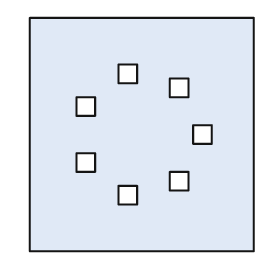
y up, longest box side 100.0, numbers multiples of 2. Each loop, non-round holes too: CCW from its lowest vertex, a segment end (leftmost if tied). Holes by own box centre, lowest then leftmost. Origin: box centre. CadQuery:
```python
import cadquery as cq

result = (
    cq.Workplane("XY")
    .moveTo(-48.0, -50.0)
    .lineTo(48.0, -50.0)
    .lineTo(48.0, 50.0)
    .lineTo(-48.0, 50.0)
    .close()
    .moveTo(-10.0, -30.0)
    .lineTo(-2.0, -30.0)
    .lineTo(-2.0, -22.0)
    .lineTo(-10.0, -22.0)
    .close()
    .moveTo(12.0, -24.0)
    .lineTo(20.0, -24.0)
    .lineTo(20.0, -16.0)
    .lineTo(12.0, -16.0)
    .close()
    .moveTo(-28.0, -16.0)
    .lineTo(-20.0, -16.0)
    .lineTo(-20.0, -8.0)
    .lineTo(-28.0, -8.0)
    .close()
    .moveTo(22.0, -4.0)
    .lineTo(30.0, -4.0)
    .lineTo(30.0, 4.0)
    .lineTo(22.0, 4.0)
    .close()
    .moveTo(-28.0, 8.0)
    .lineTo(-20.0, 8.0)
    .lineTo(-20.0, 16.0)
    .lineTo(-28.0, 16.0)
    .close()
    .moveTo(12.0, 16.0)
    .lineTo(20.0, 16.0)
    .lineTo(20.0, 24.0)
    .lineTo(12.0, 24.0)
    .close()
    .moveTo(-10.0, 22.0)
    .lineTo(-2.0, 22.0)
    .lineTo(-2.0, 30.0)
    .lineTo(-10.0, 30.0)
    .close()
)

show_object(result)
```